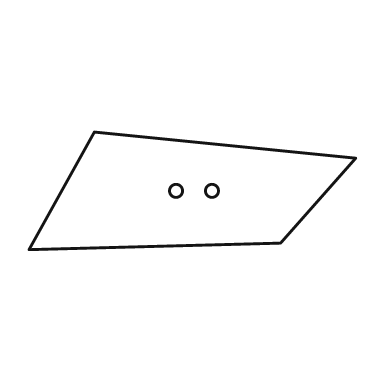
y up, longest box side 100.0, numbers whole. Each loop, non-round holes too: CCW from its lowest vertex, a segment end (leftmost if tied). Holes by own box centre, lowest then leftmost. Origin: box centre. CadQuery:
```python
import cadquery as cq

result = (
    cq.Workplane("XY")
    .moveTo(-50.0, -18.0)
    .lineTo(27.0, -16.0)
    .lineTo(50.0, 10.0)
    .lineTo(-30.0, 18.0)
    .close()
    .moveTo(-5.0, 0.0)
    .circle(2.0)
    .moveTo(6.0, 0.0)
    .circle(2.0)
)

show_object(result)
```